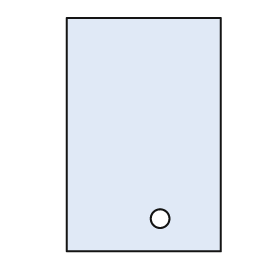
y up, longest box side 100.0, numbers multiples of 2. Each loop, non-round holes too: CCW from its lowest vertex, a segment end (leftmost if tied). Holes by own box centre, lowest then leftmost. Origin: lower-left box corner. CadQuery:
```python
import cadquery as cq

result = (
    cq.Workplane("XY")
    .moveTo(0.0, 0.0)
    .lineTo(66.0, 0.0)
    .lineTo(66.0, 100.0)
    .lineTo(0.0, 100.0)
    .close()
    .moveTo(40.0, 14.0)
    .circle(4.0)
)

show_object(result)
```